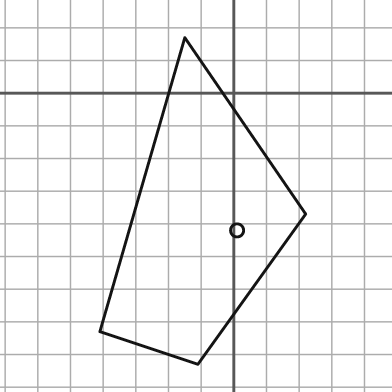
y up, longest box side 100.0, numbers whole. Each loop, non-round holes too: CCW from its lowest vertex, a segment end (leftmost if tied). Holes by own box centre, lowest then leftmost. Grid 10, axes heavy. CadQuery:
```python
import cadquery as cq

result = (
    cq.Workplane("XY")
    .moveTo(-11.0, -83.0)
    .lineTo(22.0, -37.0)
    .lineTo(-15.0, 17.0)
    .lineTo(-41.0, -73.0)
    .close()
    .moveTo(1.0, -42.0)
    .circle(2.0)
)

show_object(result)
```